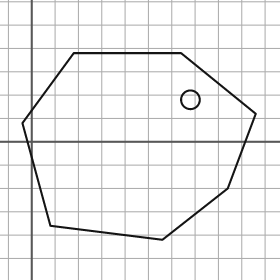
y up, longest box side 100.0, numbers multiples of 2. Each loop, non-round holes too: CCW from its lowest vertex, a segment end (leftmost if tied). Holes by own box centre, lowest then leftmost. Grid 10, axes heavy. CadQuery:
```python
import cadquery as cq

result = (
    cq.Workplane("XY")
    .moveTo(56.0, -42.0)
    .lineTo(84.0, -20.0)
    .lineTo(96.0, 12.0)
    .lineTo(64.0, 38.0)
    .lineTo(18.0, 38.0)
    .lineTo(-4.0, 8.0)
    .lineTo(8.0, -36.0)
    .close()
    .moveTo(68.0, 18.0)
    .circle(4.0)
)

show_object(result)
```